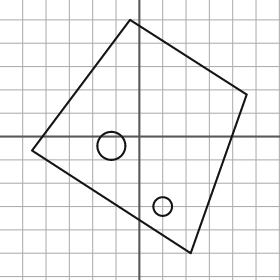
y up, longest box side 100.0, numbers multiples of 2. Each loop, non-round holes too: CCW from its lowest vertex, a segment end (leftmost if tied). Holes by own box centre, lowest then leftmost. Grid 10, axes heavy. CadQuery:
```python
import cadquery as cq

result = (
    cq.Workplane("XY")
    .moveTo(22.0, -50.0)
    .lineTo(46.0, 18.0)
    .lineTo(-4.0, 50.0)
    .lineTo(-46.0, -6.0)
    .close()
    .moveTo(10.0, -30.0)
    .circle(4.0)
    .moveTo(-12.0, -4.0)
    .circle(6.0)
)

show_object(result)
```